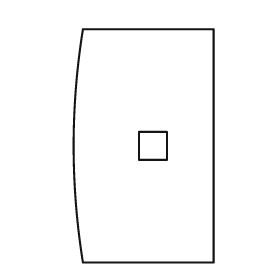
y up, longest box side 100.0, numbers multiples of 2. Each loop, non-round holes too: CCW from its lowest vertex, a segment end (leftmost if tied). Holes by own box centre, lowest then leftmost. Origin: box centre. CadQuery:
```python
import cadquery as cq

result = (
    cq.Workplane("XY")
    .moveTo(-26.0, -50.0)
    .lineTo(30.0, -50.0)
    .lineTo(30.0, 50.0)
    .lineTo(-26.0, 50.0)
    .threePointArc((-30.0, 0.0), (-26.0, -50.0))
    .close()
    .moveTo(-2.0, -6.0)
    .lineTo(10.0, -6.0)
    .lineTo(10.0, 6.0)
    .lineTo(-2.0, 6.0)
    .close()
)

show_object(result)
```